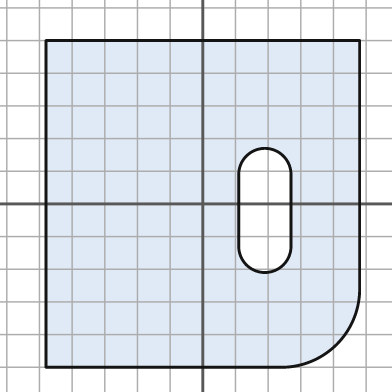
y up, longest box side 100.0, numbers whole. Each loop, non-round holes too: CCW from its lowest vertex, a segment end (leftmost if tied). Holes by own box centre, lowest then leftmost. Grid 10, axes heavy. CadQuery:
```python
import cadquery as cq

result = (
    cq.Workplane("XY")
    .moveTo(-48.0, -50.0)
    .lineTo(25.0, -50.0)
    .threePointArc((41.0, -43.0), (48.0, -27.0))
    .lineTo(48.0, 50.0)
    .lineTo(-48.0, 50.0)
    .close()
    .moveTo(11.0, -13.0)
    .threePointArc((19.0, -21.0), (27.0, -13.0))
    .lineTo(27.0, 9.0)
    .threePointArc((19.0, 17.0), (11.0, 9.0))
    .close()
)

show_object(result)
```